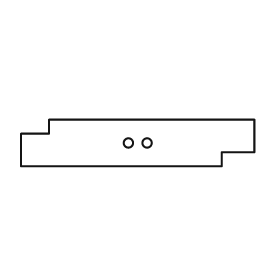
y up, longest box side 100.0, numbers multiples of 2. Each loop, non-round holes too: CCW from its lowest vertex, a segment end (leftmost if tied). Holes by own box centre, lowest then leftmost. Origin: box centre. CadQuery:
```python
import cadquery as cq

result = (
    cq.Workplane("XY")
    .moveTo(-50.0, -10.0)
    .lineTo(36.0, -10.0)
    .lineTo(36.0, -4.0)
    .lineTo(50.0, -4.0)
    .lineTo(50.0, 10.0)
    .lineTo(-38.0, 10.0)
    .lineTo(-38.0, 4.0)
    .lineTo(-50.0, 4.0)
    .close()
    .moveTo(-4.0, 0.0)
    .circle(2.0)
    .moveTo(4.0, 0.0)
    .circle(2.0)
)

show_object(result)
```